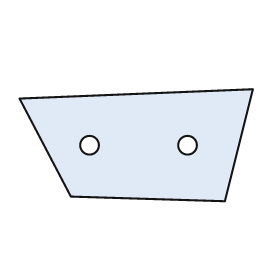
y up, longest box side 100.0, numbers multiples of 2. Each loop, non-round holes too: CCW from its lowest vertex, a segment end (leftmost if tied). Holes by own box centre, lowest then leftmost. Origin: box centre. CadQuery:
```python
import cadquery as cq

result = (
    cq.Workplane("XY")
    .moveTo(38.0, -24.0)
    .lineTo(50.0, 24.0)
    .lineTo(-50.0, 20.0)
    .lineTo(-28.0, -22.0)
    .close()
    .moveTo(-20.0, 0.0)
    .circle(4.0)
    .moveTo(22.0, 0.0)
    .circle(4.0)
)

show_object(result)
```